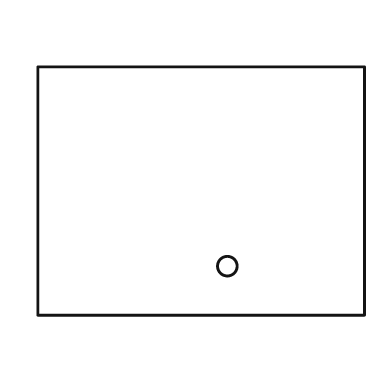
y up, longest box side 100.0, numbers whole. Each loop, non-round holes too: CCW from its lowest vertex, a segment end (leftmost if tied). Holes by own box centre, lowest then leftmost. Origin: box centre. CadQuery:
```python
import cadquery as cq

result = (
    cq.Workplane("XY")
    .moveTo(-50.0, -38.0)
    .lineTo(50.0, -38.0)
    .lineTo(50.0, 38.0)
    .lineTo(-50.0, 38.0)
    .close()
    .moveTo(8.0, -23.0)
    .circle(3.0)
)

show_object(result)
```